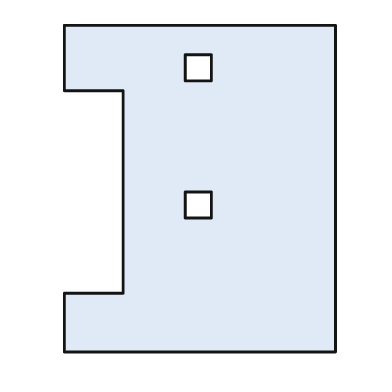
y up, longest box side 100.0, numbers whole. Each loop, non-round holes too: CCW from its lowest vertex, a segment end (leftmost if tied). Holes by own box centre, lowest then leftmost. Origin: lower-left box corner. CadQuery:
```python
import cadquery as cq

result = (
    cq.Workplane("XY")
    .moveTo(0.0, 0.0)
    .lineTo(83.0, 0.0)
    .lineTo(83.0, 100.0)
    .lineTo(0.0, 100.0)
    .lineTo(0.0, 80.0)
    .lineTo(18.0, 80.0)
    .lineTo(18.0, 18.0)
    .lineTo(0.0, 18.0)
    .close()
    .moveTo(37.0, 41.0)
    .lineTo(45.0, 41.0)
    .lineTo(45.0, 49.0)
    .lineTo(37.0, 49.0)
    .close()
    .moveTo(37.0, 83.0)
    .lineTo(45.0, 83.0)
    .lineTo(45.0, 91.0)
    .lineTo(37.0, 91.0)
    .close()
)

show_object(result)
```